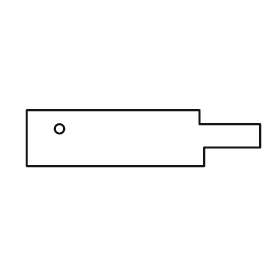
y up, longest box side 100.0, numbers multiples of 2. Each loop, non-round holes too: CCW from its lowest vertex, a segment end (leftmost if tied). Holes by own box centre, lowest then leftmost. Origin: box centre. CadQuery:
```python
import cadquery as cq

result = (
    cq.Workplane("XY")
    .moveTo(-50.0, -12.0)
    .lineTo(26.0, -12.0)
    .lineTo(26.0, -4.0)
    .lineTo(50.0, -4.0)
    .lineTo(50.0, 6.0)
    .lineTo(24.0, 6.0)
    .lineTo(24.0, 12.0)
    .lineTo(-50.0, 12.0)
    .close()
    .moveTo(-36.0, 4.0)
    .circle(2.0)
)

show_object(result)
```